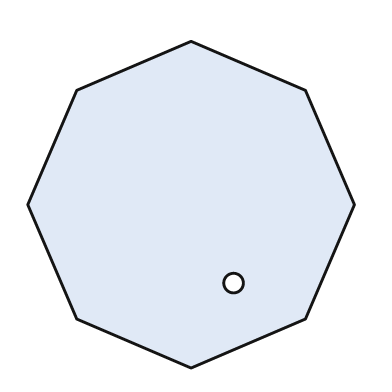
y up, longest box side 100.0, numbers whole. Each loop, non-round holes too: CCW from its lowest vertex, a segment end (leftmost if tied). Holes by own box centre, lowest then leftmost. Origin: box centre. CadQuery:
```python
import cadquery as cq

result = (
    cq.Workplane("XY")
    .moveTo(0.0, -50.0)
    .lineTo(35.0, -35.0)
    .lineTo(50.0, 0.0)
    .lineTo(35.0, 35.0)
    .lineTo(0.0, 50.0)
    .lineTo(-35.0, 35.0)
    .lineTo(-50.0, 0.0)
    .lineTo(-35.0, -35.0)
    .close()
    .moveTo(13.0, -24.0)
    .circle(3.0)
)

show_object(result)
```